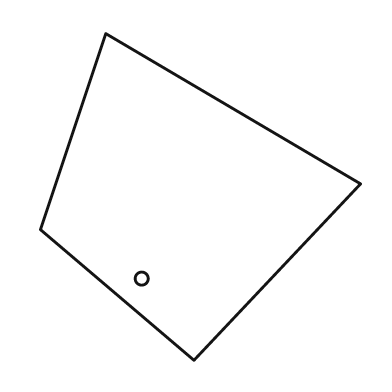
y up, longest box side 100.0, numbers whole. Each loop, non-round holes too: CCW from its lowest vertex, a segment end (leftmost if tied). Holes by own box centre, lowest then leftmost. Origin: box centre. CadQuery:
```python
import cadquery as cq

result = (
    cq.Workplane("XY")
    .moveTo(-2.0, -50.0)
    .lineTo(49.0, 4.0)
    .lineTo(-29.0, 50.0)
    .lineTo(-49.0, -10.0)
    .close()
    .moveTo(-18.0, -25.0)
    .circle(2.0)
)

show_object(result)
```